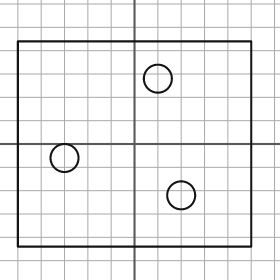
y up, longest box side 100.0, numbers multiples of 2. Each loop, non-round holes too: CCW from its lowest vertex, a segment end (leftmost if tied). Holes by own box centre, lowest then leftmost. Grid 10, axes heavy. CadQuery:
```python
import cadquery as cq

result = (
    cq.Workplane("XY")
    .moveTo(-50.0, -44.0)
    .lineTo(50.0, -44.0)
    .lineTo(50.0, 44.0)
    .lineTo(-50.0, 44.0)
    .close()
    .moveTo(20.0, -22.0)
    .circle(6.0)
    .moveTo(-30.0, -6.0)
    .circle(6.0)
    .moveTo(10.0, 28.0)
    .circle(6.0)
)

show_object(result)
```